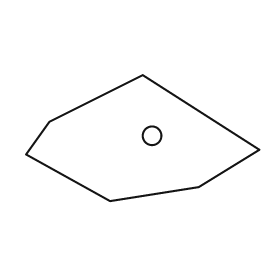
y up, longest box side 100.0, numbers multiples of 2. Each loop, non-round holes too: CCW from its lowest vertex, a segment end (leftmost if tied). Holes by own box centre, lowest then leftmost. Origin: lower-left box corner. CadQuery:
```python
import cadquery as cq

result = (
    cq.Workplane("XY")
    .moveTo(36.0, 0.0)
    .lineTo(74.0, 6.0)
    .lineTo(100.0, 22.0)
    .lineTo(50.0, 54.0)
    .lineTo(10.0, 34.0)
    .lineTo(0.0, 20.0)
    .close()
    .moveTo(54.0, 28.0)
    .circle(4.0)
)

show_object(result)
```